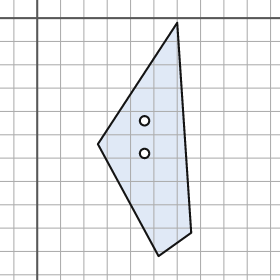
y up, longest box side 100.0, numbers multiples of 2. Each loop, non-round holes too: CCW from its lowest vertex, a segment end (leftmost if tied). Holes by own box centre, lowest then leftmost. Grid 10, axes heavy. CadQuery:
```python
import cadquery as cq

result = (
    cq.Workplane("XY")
    .moveTo(52.0, -102.0)
    .lineTo(66.0, -92.0)
    .lineTo(60.0, -2.0)
    .lineTo(26.0, -54.0)
    .close()
    .moveTo(46.0, -58.0)
    .circle(2.0)
    .moveTo(46.0, -44.0)
    .circle(2.0)
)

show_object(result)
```